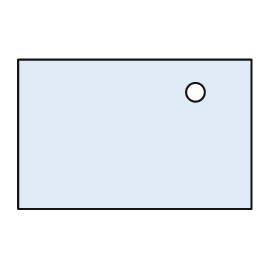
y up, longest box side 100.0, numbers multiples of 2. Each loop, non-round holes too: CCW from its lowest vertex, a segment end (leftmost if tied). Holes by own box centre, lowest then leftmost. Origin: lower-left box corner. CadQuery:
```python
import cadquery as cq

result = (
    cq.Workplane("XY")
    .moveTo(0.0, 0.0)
    .lineTo(100.0, 0.0)
    .lineTo(100.0, 64.0)
    .lineTo(0.0, 64.0)
    .close()
    .moveTo(76.0, 50.0)
    .circle(4.0)
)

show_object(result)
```